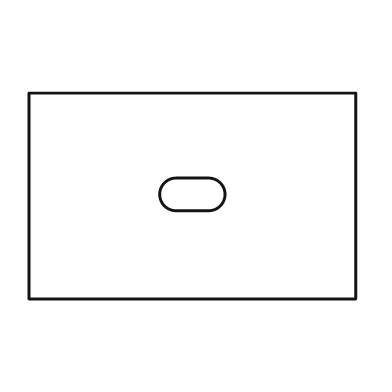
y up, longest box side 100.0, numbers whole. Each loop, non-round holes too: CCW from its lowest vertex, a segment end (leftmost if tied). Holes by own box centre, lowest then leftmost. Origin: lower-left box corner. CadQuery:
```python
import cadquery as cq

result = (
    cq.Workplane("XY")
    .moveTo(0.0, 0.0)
    .lineTo(100.0, 0.0)
    .lineTo(100.0, 63.0)
    .lineTo(0.0, 63.0)
    .close()
    .moveTo(45.0, 27.0)
    .lineTo(55.0, 27.0)
    .threePointArc((60.0, 32.0), (55.0, 37.0))
    .lineTo(45.0, 37.0)
    .threePointArc((40.0, 32.0), (45.0, 27.0))
    .close()
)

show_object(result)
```